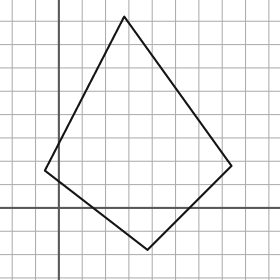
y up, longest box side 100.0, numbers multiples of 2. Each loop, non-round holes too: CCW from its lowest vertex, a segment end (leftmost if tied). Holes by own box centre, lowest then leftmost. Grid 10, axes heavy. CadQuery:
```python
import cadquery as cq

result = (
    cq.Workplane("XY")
    .moveTo(38.0, -18.0)
    .lineTo(74.0, 18.0)
    .lineTo(28.0, 82.0)
    .lineTo(-6.0, 16.0)
    .close()
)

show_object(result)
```